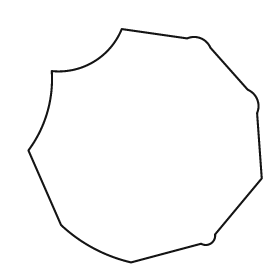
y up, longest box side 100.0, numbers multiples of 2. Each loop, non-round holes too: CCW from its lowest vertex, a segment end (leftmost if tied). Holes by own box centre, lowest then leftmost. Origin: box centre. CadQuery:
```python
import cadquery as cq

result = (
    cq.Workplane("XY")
    .moveTo(-6.0, -50.0)
    .lineTo(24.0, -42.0)
    .threePointArc((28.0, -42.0), (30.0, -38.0))
    .lineTo(50.0, -14.0)
    .lineTo(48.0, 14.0)
    .threePointArc((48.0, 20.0), (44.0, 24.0))
    .lineTo(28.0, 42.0)
    .threePointArc((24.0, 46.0), (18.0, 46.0))
    .lineTo(-10.0, 50.0)
    .threePointArc((-22.0, 36.0), (-40.0, 32.0))
    .threePointArc((-42.0, 14.0), (-50.0, -2.0))
    .lineTo(-36.0, -34.0)
    .threePointArc((-22.0, -44.0), (-6.0, -50.0))
    .close()
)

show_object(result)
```